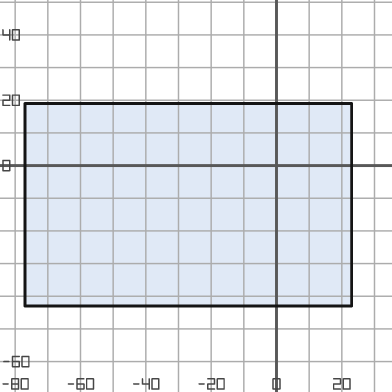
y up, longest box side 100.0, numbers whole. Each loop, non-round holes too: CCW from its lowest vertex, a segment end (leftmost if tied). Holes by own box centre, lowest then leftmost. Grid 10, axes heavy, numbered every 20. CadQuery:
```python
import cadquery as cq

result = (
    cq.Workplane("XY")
    .moveTo(-77.0, -43.0)
    .lineTo(23.0, -43.0)
    .lineTo(23.0, 19.0)
    .lineTo(-77.0, 19.0)
    .close()
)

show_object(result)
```